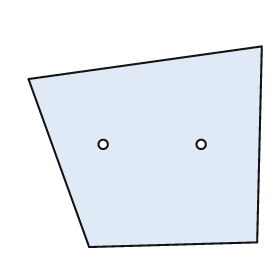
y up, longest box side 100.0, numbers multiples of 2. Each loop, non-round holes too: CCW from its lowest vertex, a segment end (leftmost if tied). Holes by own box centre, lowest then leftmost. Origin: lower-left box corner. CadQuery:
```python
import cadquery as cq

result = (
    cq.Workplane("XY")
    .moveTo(26.0, 0.0)
    .lineTo(98.0, 2.0)
    .lineTo(100.0, 86.0)
    .lineTo(0.0, 72.0)
    .close()
    .moveTo(32.0, 44.0)
    .circle(2.0)
    .moveTo(74.0, 44.0)
    .circle(2.0)
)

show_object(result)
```